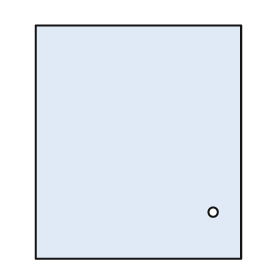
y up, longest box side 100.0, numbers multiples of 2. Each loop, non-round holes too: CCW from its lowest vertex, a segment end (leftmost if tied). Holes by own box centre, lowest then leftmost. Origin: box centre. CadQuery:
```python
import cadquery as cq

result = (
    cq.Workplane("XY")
    .moveTo(-44.0, -50.0)
    .lineTo(44.0, -50.0)
    .lineTo(44.0, 50.0)
    .lineTo(-44.0, 50.0)
    .close()
    .moveTo(32.0, -30.0)
    .circle(2.0)
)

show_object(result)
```